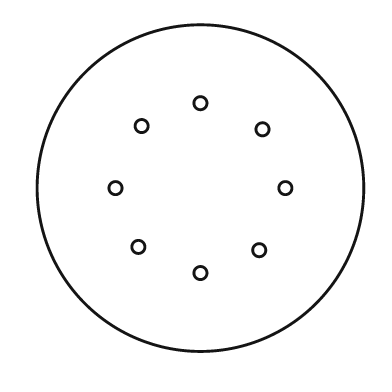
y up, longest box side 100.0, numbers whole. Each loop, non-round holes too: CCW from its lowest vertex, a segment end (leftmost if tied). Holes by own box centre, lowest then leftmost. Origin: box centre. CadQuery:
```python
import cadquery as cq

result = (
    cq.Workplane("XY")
    .moveTo(0.0, 0.0)
    .circle(50.0)
    .moveTo(0.0, -26.0)
    .circle(2.0)
    .moveTo(18.0, -19.0)
    .circle(2.0)
    .moveTo(-19.0, -18.0)
    .circle(2.0)
    .moveTo(-26.0, 0.0)
    .circle(2.0)
    .moveTo(26.0, 0.0)
    .circle(2.0)
    .moveTo(19.0, 18.0)
    .circle(2.0)
    .moveTo(-18.0, 19.0)
    .circle(2.0)
    .moveTo(0.0, 26.0)
    .circle(2.0)
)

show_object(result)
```